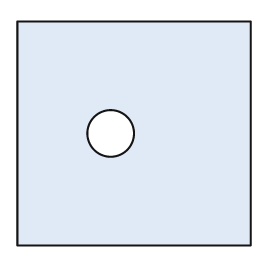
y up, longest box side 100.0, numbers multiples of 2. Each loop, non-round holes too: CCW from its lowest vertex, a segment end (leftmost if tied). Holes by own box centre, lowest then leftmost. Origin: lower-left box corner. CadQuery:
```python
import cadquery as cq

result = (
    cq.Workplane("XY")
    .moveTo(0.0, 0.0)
    .lineTo(100.0, 0.0)
    .lineTo(100.0, 96.0)
    .lineTo(0.0, 96.0)
    .close()
    .moveTo(40.0, 48.0)
    .circle(10.0)
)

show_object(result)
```